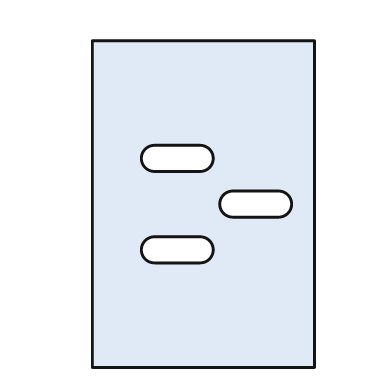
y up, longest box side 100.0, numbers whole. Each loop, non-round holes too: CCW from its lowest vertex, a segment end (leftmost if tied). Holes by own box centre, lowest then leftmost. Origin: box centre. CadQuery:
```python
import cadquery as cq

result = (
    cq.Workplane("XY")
    .moveTo(-34.0, -50.0)
    .lineTo(34.0, -50.0)
    .lineTo(34.0, 50.0)
    .lineTo(-34.0, 50.0)
    .close()
    .moveTo(-15.0, -18.0)
    .lineTo(-1.0, -18.0)
    .threePointArc((3.0, -14.0), (-1.0, -10.0))
    .lineTo(-15.0, -10.0)
    .threePointArc((-19.0, -14.0), (-15.0, -18.0))
    .close()
    .moveTo(9.0, -4.0)
    .lineTo(23.0, -4.0)
    .threePointArc((27.0, 0.0), (23.0, 4.0))
    .lineTo(9.0, 4.0)
    .threePointArc((5.0, 0.0), (9.0, -4.0))
    .close()
    .moveTo(-15.0, 10.0)
    .lineTo(-1.0, 10.0)
    .threePointArc((3.0, 14.0), (-1.0, 18.0))
    .lineTo(-15.0, 18.0)
    .threePointArc((-19.0, 14.0), (-15.0, 10.0))
    .close()
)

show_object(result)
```